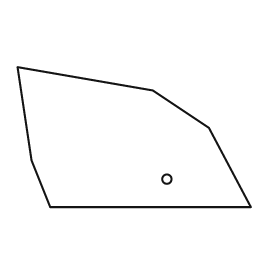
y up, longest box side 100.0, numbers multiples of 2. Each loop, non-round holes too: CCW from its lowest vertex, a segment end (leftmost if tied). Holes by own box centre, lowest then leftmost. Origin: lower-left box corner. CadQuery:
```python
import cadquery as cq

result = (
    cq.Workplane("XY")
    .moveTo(14.0, 0.0)
    .lineTo(100.0, 0.0)
    .lineTo(82.0, 34.0)
    .lineTo(58.0, 50.0)
    .lineTo(0.0, 60.0)
    .lineTo(6.0, 20.0)
    .close()
    .moveTo(64.0, 12.0)
    .circle(2.0)
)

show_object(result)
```